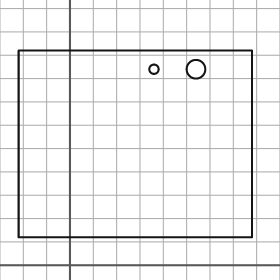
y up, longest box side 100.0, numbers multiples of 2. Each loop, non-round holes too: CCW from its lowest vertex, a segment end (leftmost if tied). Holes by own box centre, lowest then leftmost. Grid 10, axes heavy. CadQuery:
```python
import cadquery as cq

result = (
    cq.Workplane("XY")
    .moveTo(-22.0, 12.0)
    .lineTo(78.0, 12.0)
    .lineTo(78.0, 92.0)
    .lineTo(-22.0, 92.0)
    .close()
    .moveTo(36.0, 84.0)
    .circle(2.0)
    .moveTo(54.0, 84.0)
    .circle(4.0)
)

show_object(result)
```